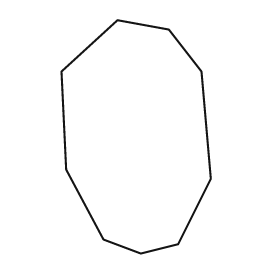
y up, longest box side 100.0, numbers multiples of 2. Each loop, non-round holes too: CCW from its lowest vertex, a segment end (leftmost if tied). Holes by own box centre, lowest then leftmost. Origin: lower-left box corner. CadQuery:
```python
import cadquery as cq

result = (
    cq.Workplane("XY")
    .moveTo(34.0, 0.0)
    .lineTo(50.0, 4.0)
    .lineTo(64.0, 32.0)
    .lineTo(60.0, 78.0)
    .lineTo(46.0, 96.0)
    .lineTo(24.0, 100.0)
    .lineTo(0.0, 78.0)
    .lineTo(2.0, 36.0)
    .lineTo(18.0, 6.0)
    .close()
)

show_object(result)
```